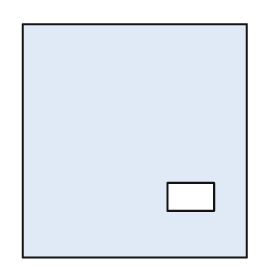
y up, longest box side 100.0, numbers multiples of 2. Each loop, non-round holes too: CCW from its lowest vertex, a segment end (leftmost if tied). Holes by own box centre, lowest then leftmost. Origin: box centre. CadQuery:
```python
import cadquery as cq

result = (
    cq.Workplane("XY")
    .moveTo(-48.0, -50.0)
    .lineTo(48.0, -50.0)
    .lineTo(48.0, 50.0)
    .lineTo(-48.0, 50.0)
    .close()
    .moveTo(14.0, -30.0)
    .lineTo(34.0, -30.0)
    .lineTo(34.0, -18.0)
    .lineTo(14.0, -18.0)
    .close()
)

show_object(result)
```